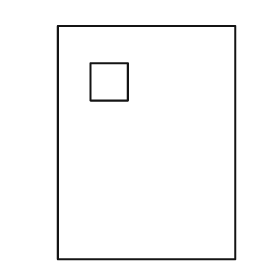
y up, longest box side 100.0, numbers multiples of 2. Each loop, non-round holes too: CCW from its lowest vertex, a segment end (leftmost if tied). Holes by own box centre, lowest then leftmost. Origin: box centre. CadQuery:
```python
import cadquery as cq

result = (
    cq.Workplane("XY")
    .moveTo(-38.0, -50.0)
    .lineTo(38.0, -50.0)
    .lineTo(38.0, 50.0)
    .lineTo(-38.0, 50.0)
    .close()
    .moveTo(-24.0, 18.0)
    .lineTo(-8.0, 18.0)
    .lineTo(-8.0, 34.0)
    .lineTo(-24.0, 34.0)
    .close()
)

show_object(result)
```